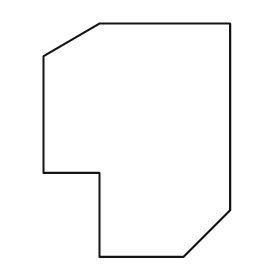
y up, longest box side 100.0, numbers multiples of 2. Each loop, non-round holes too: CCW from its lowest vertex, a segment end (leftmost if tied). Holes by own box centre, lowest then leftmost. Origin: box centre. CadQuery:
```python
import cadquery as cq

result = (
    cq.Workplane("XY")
    .moveTo(-16.0, -50.0)
    .lineTo(20.0, -50.0)
    .lineTo(40.0, -30.0)
    .lineTo(40.0, 50.0)
    .lineTo(-16.0, 50.0)
    .lineTo(-40.0, 36.0)
    .lineTo(-40.0, -14.0)
    .lineTo(-16.0, -14.0)
    .close()
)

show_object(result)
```